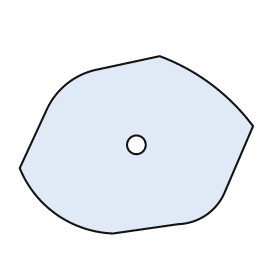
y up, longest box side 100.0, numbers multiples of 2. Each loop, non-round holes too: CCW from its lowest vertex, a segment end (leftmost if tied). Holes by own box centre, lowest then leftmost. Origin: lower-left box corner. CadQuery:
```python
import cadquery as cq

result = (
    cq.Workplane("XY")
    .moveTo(40.0, 0.0)
    .lineTo(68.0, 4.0)
    .threePointArc((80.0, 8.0), (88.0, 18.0))
    .lineTo(100.0, 46.0)
    .threePointArc((82.0, 64.0), (60.0, 76.0))
    .lineTo(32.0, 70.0)
    .threePointArc((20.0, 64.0), (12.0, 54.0))
    .lineTo(0.0, 28.0)
    .threePointArc((16.0, 8.0), (40.0, 0.0))
    .close()
    .moveTo(50.0, 38.0)
    .circle(4.0)
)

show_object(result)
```